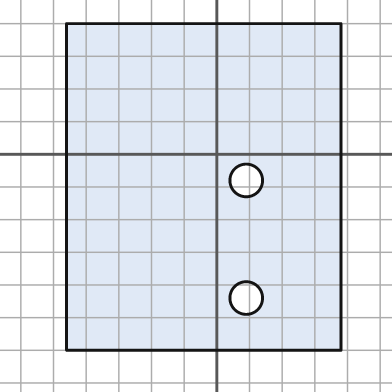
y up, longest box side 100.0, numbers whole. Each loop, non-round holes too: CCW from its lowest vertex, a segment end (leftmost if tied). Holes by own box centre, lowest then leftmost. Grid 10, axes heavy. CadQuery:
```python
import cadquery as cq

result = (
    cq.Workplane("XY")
    .moveTo(-46.0, -60.0)
    .lineTo(38.0, -60.0)
    .lineTo(38.0, 40.0)
    .lineTo(-46.0, 40.0)
    .close()
    .moveTo(9.0, -44.0)
    .circle(5.0)
    .moveTo(9.0, -8.0)
    .circle(5.0)
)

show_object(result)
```